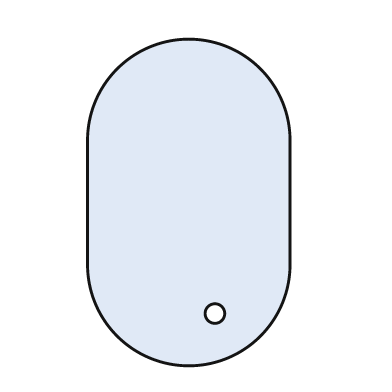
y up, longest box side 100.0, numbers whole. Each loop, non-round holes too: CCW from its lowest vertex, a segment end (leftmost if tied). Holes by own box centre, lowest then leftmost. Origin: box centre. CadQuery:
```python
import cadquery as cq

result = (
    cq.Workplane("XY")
    .moveTo(-31.0, -19.0)
    .threePointArc((0.0, -50.0), (31.0, -19.0))
    .lineTo(31.0, 19.0)
    .threePointArc((0.0, 50.0), (-31.0, 19.0))
    .close()
    .moveTo(8.0, -34.0)
    .circle(3.0)
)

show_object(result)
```